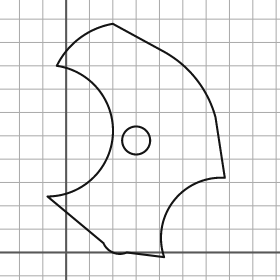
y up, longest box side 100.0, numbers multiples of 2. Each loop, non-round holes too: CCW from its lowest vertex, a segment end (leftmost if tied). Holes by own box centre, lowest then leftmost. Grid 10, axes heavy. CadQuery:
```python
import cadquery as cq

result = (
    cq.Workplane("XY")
    .moveTo(42.0, -2.0)
    .threePointArc((46.0, 22.0), (68.0, 32.0))
    .lineTo(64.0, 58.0)
    .threePointArc((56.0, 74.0), (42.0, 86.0))
    .lineTo(20.0, 98.0)
    .threePointArc((6.0, 92.0), (-4.0, 80.0))
    .threePointArc((20.0, 50.0), (-8.0, 24.0))
    .lineTo(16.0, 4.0)
    .threePointArc((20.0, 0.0), (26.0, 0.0))
    .close()
    .moveTo(30.0, 48.0)
    .circle(6.0)
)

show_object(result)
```